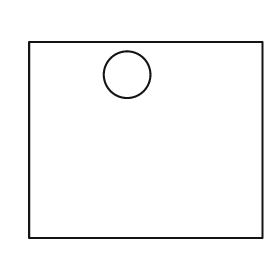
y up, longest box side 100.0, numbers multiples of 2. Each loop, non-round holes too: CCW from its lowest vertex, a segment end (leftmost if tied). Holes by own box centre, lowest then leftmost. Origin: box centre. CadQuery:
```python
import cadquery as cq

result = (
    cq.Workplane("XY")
    .moveTo(-50.0, -42.0)
    .lineTo(50.0, -42.0)
    .lineTo(50.0, 42.0)
    .lineTo(-50.0, 42.0)
    .close()
    .moveTo(-8.0, 28.0)
    .circle(10.0)
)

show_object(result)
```